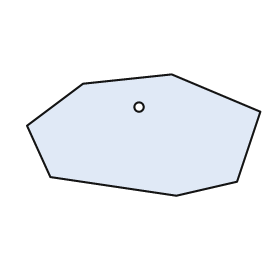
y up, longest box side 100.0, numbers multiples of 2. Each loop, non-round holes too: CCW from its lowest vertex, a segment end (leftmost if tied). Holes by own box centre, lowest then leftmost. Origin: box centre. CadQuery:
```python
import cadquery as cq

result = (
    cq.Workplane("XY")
    .moveTo(14.0, -26.0)
    .lineTo(40.0, -20.0)
    .lineTo(50.0, 10.0)
    .lineTo(12.0, 26.0)
    .lineTo(-26.0, 22.0)
    .lineTo(-50.0, 4.0)
    .lineTo(-40.0, -18.0)
    .close()
    .moveTo(-2.0, 12.0)
    .circle(2.0)
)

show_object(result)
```